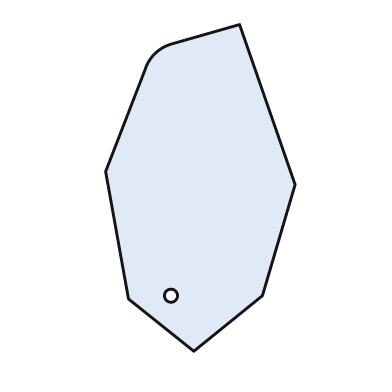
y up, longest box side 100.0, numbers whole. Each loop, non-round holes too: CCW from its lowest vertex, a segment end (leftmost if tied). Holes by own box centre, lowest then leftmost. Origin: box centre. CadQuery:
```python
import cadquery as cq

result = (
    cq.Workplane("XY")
    .moveTo(-2.0, -50.0)
    .lineTo(19.0, -33.0)
    .lineTo(29.0, 1.0)
    .lineTo(12.0, 50.0)
    .lineTo(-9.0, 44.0)
    .threePointArc((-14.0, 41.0), (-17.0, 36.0))
    .lineTo(-29.0, 5.0)
    .lineTo(-22.0, -34.0)
    .close()
    .moveTo(-9.0, -33.0)
    .circle(2.0)
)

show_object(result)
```